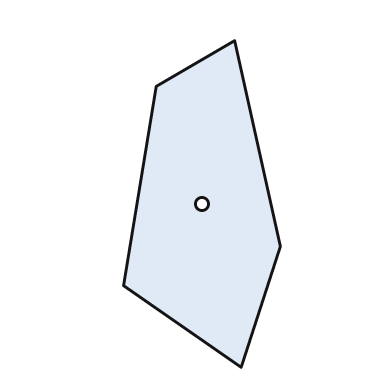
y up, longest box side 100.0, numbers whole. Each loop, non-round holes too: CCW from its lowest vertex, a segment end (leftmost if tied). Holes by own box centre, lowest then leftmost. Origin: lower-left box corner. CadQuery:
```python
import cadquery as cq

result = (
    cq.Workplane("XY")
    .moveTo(36.0, 0.0)
    .lineTo(48.0, 37.0)
    .lineTo(34.0, 100.0)
    .lineTo(10.0, 86.0)
    .lineTo(0.0, 25.0)
    .close()
    .moveTo(24.0, 50.0)
    .circle(2.0)
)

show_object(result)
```